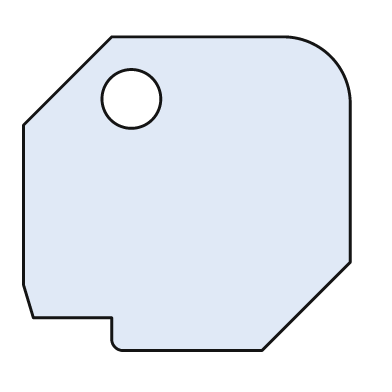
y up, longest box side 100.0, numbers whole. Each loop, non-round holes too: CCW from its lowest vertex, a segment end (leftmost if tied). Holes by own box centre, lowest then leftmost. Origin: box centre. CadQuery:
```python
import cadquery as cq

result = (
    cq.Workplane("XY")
    .moveTo(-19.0, -48.0)
    .lineTo(23.0, -48.0)
    .lineTo(50.0, -21.0)
    .lineTo(50.0, 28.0)
    .threePointArc((44.0, 42.0), (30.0, 48.0))
    .lineTo(-23.0, 48.0)
    .lineTo(-50.0, 21.0)
    .lineTo(-50.0, -28.0)
    .lineTo(-47.0, -38.0)
    .lineTo(-23.0, -38.0)
    .lineTo(-23.0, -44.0)
    .threePointArc((-22.0, -47.0), (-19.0, -48.0))
    .close()
    .moveTo(-17.0, 29.0)
    .circle(9.0)
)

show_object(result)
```